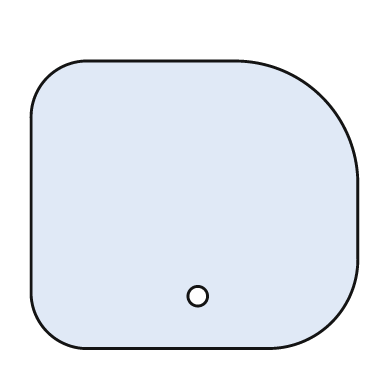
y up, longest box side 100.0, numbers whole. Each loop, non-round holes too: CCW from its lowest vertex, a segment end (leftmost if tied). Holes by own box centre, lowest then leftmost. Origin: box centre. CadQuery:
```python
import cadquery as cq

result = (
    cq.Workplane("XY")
    .moveTo(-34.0, -44.0)
    .lineTo(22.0, -44.0)
    .threePointArc((42.0, -36.0), (50.0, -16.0))
    .lineTo(50.0, 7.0)
    .threePointArc((39.0, 33.0), (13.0, 44.0))
    .lineTo(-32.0, 44.0)
    .threePointArc((-45.0, 39.0), (-50.0, 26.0))
    .lineTo(-50.0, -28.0)
    .threePointArc((-45.0, -39.0), (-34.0, -44.0))
    .close()
    .moveTo(1.0, -28.0)
    .circle(3.0)
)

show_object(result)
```